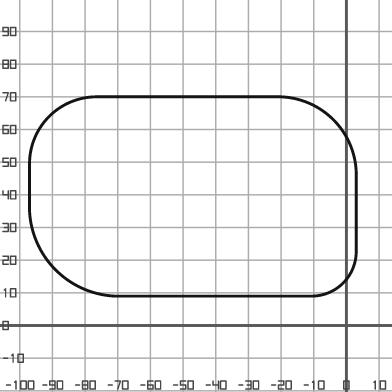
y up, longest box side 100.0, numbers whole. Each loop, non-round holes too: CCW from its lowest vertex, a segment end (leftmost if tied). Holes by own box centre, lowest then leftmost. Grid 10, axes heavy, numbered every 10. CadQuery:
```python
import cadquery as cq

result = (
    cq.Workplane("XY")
    .moveTo(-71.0, 9.0)
    .lineTo(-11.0, 9.0)
    .threePointArc((-1.0, 13.0), (3.0, 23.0))
    .lineTo(3.0, 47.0)
    .threePointArc((-4.0, 63.0), (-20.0, 70.0))
    .lineTo(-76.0, 70.0)
    .threePointArc((-91.0, 64.0), (-97.0, 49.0))
    .lineTo(-97.0, 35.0)
    .threePointArc((-89.0, 17.0), (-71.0, 9.0))
    .close()
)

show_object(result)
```